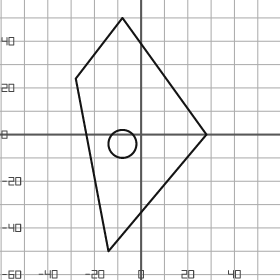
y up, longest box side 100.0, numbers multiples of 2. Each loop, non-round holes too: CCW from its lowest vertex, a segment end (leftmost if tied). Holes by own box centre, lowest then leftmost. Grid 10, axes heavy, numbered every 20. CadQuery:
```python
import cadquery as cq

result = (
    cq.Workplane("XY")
    .moveTo(-14.0, -50.0)
    .lineTo(28.0, 0.0)
    .lineTo(-8.0, 50.0)
    .lineTo(-28.0, 24.0)
    .close()
    .moveTo(-8.0, -4.0)
    .circle(6.0)
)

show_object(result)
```